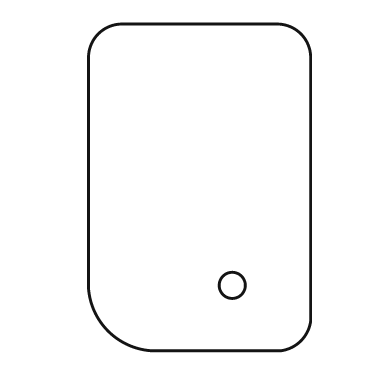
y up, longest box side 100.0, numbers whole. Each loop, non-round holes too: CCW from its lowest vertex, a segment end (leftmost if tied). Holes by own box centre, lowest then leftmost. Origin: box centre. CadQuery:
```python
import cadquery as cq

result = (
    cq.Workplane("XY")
    .moveTo(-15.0, -50.0)
    .lineTo(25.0, -50.0)
    .threePointArc((31.0, -47.0), (34.0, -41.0))
    .lineTo(34.0, 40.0)
    .threePointArc((31.0, 47.0), (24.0, 50.0))
    .lineTo(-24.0, 50.0)
    .threePointArc((-31.0, 47.0), (-34.0, 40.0))
    .lineTo(-34.0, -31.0)
    .threePointArc((-28.0, -44.0), (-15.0, -50.0))
    .close()
    .moveTo(10.0, -30.0)
    .circle(4.0)
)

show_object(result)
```